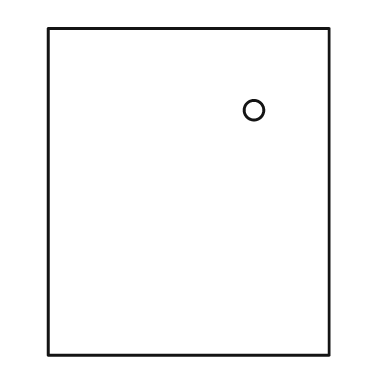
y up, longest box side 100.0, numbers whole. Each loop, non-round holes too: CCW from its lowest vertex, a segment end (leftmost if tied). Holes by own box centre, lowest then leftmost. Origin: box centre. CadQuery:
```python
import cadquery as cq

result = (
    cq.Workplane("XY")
    .moveTo(-43.0, -50.0)
    .lineTo(43.0, -50.0)
    .lineTo(43.0, 50.0)
    .lineTo(-43.0, 50.0)
    .close()
    .moveTo(20.0, 25.0)
    .circle(3.0)
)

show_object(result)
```